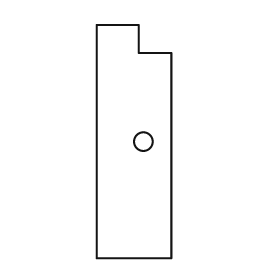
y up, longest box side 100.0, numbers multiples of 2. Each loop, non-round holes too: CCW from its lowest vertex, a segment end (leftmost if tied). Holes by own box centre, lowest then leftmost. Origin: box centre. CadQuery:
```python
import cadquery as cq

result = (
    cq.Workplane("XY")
    .moveTo(-16.0, -50.0)
    .lineTo(16.0, -50.0)
    .lineTo(16.0, 38.0)
    .lineTo(2.0, 38.0)
    .lineTo(2.0, 50.0)
    .lineTo(-16.0, 50.0)
    .close()
    .moveTo(4.0, 0.0)
    .circle(4.0)
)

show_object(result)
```